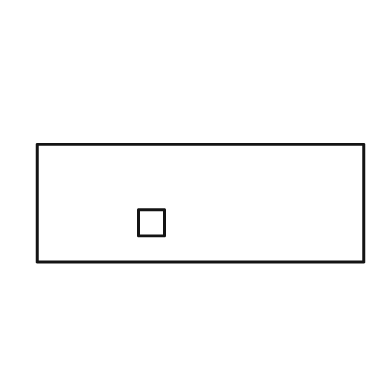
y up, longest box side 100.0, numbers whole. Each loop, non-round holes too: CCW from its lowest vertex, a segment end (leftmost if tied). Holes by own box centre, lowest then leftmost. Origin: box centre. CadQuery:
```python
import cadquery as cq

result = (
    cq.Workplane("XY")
    .moveTo(-50.0, -18.0)
    .lineTo(50.0, -18.0)
    .lineTo(50.0, 18.0)
    .lineTo(-50.0, 18.0)
    .close()
    .moveTo(-19.0, -10.0)
    .lineTo(-11.0, -10.0)
    .lineTo(-11.0, -2.0)
    .lineTo(-19.0, -2.0)
    .close()
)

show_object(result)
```